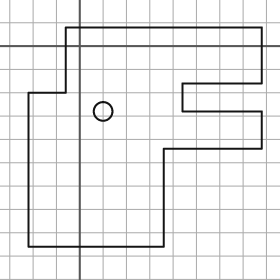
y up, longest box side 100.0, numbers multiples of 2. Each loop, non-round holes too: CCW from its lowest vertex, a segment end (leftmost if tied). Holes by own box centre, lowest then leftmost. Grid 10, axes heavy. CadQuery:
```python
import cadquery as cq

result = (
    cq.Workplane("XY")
    .moveTo(-22.0, -86.0)
    .lineTo(36.0, -86.0)
    .lineTo(36.0, -44.0)
    .lineTo(78.0, -44.0)
    .lineTo(78.0, -28.0)
    .lineTo(44.0, -28.0)
    .lineTo(44.0, -16.0)
    .lineTo(78.0, -16.0)
    .lineTo(78.0, 8.0)
    .lineTo(-6.0, 8.0)
    .lineTo(-6.0, -20.0)
    .lineTo(-22.0, -20.0)
    .close()
    .moveTo(10.0, -28.0)
    .circle(4.0)
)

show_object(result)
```